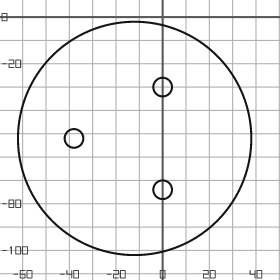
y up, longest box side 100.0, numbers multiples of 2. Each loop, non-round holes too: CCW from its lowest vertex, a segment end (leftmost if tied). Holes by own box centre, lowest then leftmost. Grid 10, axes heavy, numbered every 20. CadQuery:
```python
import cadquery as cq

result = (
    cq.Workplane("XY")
    .moveTo(-12.0, -52.0)
    .circle(50.0)
    .moveTo(0.0, -74.0)
    .circle(4.0)
    .moveTo(-38.0, -52.0)
    .circle(4.0)
    .moveTo(0.0, -30.0)
    .circle(4.0)
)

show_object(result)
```